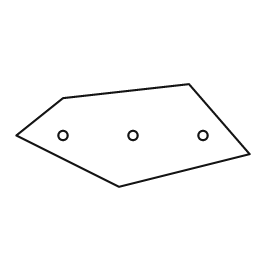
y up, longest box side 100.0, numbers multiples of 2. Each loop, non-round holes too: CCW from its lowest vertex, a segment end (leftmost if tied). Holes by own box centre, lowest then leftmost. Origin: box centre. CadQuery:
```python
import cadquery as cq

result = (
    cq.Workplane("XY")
    .moveTo(-6.0, -22.0)
    .lineTo(50.0, -8.0)
    .lineTo(24.0, 22.0)
    .lineTo(-30.0, 16.0)
    .lineTo(-50.0, 0.0)
    .close()
    .moveTo(-30.0, 0.0)
    .circle(2.0)
    .moveTo(0.0, 0.0)
    .circle(2.0)
    .moveTo(30.0, 0.0)
    .circle(2.0)
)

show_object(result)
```